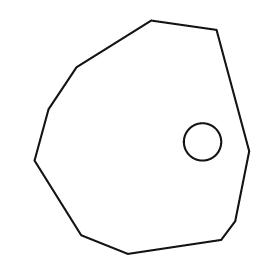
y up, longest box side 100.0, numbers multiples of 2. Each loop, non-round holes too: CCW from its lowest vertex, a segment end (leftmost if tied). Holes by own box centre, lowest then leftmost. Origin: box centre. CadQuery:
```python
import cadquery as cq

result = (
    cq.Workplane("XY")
    .moveTo(-6.0, -50.0)
    .lineTo(34.0, -44.0)
    .lineTo(40.0, -36.0)
    .lineTo(46.0, -6.0)
    .lineTo(32.0, 46.0)
    .lineTo(4.0, 50.0)
    .lineTo(-28.0, 30.0)
    .lineTo(-40.0, 12.0)
    .lineTo(-46.0, -10.0)
    .lineTo(-26.0, -42.0)
    .close()
    .moveTo(26.0, -2.0)
    .circle(8.0)
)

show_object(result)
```